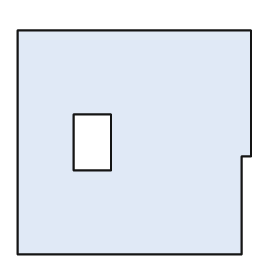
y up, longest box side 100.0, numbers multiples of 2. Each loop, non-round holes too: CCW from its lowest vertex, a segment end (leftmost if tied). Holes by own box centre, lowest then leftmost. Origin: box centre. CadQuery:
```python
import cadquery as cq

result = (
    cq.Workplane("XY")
    .moveTo(-50.0, -48.0)
    .lineTo(46.0, -48.0)
    .lineTo(46.0, -6.0)
    .lineTo(50.0, -6.0)
    .lineTo(50.0, 48.0)
    .lineTo(-50.0, 48.0)
    .close()
    .moveTo(-26.0, -12.0)
    .lineTo(-10.0, -12.0)
    .lineTo(-10.0, 12.0)
    .lineTo(-26.0, 12.0)
    .close()
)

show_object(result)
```